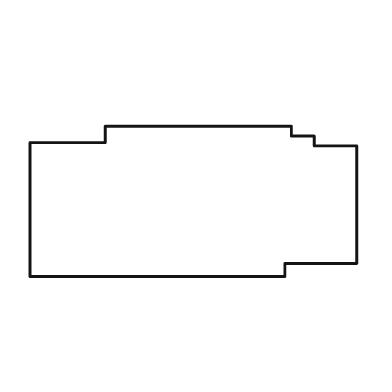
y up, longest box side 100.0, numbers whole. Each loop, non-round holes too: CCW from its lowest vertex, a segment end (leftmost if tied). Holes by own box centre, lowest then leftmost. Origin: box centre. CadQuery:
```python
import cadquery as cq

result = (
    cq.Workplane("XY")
    .moveTo(-50.0, -23.0)
    .lineTo(28.0, -23.0)
    .lineTo(28.0, -19.0)
    .lineTo(50.0, -19.0)
    .lineTo(50.0, 17.0)
    .lineTo(37.0, 17.0)
    .lineTo(37.0, 20.0)
    .lineTo(30.0, 20.0)
    .lineTo(30.0, 23.0)
    .lineTo(-27.0, 23.0)
    .lineTo(-27.0, 18.0)
    .lineTo(-50.0, 18.0)
    .close()
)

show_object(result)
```